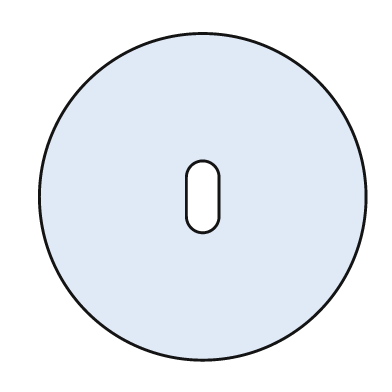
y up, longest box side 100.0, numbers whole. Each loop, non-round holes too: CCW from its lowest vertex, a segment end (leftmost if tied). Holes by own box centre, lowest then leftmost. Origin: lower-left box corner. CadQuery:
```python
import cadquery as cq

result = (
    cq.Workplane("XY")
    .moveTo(50.0, 50.0)
    .circle(50.0)
    .moveTo(45.0, 44.0)
    .threePointArc((50.0, 39.0), (55.0, 44.0))
    .lineTo(55.0, 56.0)
    .threePointArc((50.0, 61.0), (45.0, 56.0))
    .close()
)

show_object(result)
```